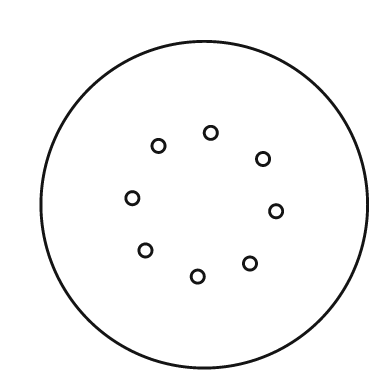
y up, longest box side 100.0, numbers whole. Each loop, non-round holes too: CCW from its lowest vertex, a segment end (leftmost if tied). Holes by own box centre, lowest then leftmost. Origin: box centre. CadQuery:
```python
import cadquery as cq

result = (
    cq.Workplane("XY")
    .moveTo(0.0, 0.0)
    .circle(50.0)
    .moveTo(-2.0, -22.0)
    .circle(2.0)
    .moveTo(14.0, -18.0)
    .circle(2.0)
    .moveTo(-18.0, -14.0)
    .circle(2.0)
    .moveTo(22.0, -2.0)
    .circle(2.0)
    .moveTo(-22.0, 2.0)
    .circle(2.0)
    .moveTo(18.0, 14.0)
    .circle(2.0)
    .moveTo(-14.0, 18.0)
    .circle(2.0)
    .moveTo(2.0, 22.0)
    .circle(2.0)
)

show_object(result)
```